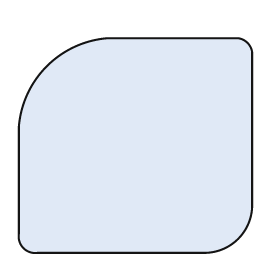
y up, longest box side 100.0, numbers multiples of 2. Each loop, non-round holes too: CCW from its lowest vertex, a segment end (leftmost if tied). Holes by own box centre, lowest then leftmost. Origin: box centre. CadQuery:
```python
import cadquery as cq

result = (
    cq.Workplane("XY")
    .moveTo(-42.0, -46.0)
    .lineTo(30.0, -46.0)
    .threePointArc((44.0, -40.0), (50.0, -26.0))
    .lineTo(50.0, 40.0)
    .threePointArc((48.0, 44.0), (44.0, 46.0))
    .lineTo(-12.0, 46.0)
    .threePointArc((-38.0, 34.0), (-50.0, 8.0))
    .lineTo(-50.0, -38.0)
    .threePointArc((-48.0, -44.0), (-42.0, -46.0))
    .close()
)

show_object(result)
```